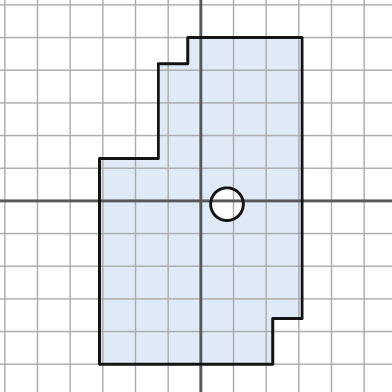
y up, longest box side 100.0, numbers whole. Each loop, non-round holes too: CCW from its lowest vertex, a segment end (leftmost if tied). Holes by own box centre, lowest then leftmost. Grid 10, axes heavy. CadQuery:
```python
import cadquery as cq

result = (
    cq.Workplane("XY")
    .moveTo(-31.0, -50.0)
    .lineTo(22.0, -50.0)
    .lineTo(22.0, -36.0)
    .lineTo(31.0, -36.0)
    .lineTo(31.0, 50.0)
    .lineTo(-4.0, 50.0)
    .lineTo(-4.0, 42.0)
    .lineTo(-13.0, 42.0)
    .lineTo(-13.0, 13.0)
    .lineTo(-31.0, 13.0)
    .close()
    .moveTo(8.0, -1.0)
    .circle(5.0)
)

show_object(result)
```